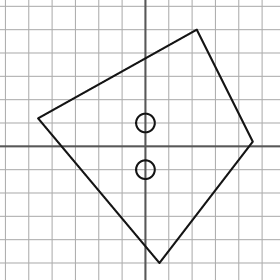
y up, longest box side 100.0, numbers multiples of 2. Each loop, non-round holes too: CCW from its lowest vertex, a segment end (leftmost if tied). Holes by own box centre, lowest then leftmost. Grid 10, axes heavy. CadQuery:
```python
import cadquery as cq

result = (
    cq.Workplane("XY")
    .moveTo(6.0, -50.0)
    .lineTo(46.0, 2.0)
    .lineTo(22.0, 50.0)
    .lineTo(-46.0, 12.0)
    .close()
    .moveTo(0.0, -10.0)
    .circle(4.0)
    .moveTo(0.0, 10.0)
    .circle(4.0)
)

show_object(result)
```